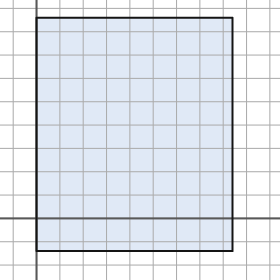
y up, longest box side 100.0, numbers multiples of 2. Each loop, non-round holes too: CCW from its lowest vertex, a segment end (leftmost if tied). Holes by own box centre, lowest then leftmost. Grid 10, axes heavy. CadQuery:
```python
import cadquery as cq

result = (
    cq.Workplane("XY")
    .moveTo(0.0, -14.0)
    .lineTo(84.0, -14.0)
    .lineTo(84.0, 86.0)
    .lineTo(0.0, 86.0)
    .close()
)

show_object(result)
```